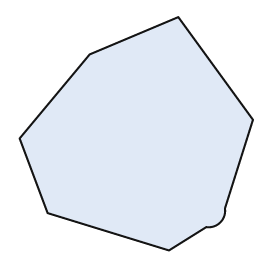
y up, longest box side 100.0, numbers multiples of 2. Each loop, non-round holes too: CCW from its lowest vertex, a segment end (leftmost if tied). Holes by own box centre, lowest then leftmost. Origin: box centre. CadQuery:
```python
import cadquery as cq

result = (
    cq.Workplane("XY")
    .moveTo(14.0, -50.0)
    .lineTo(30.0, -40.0)
    .threePointArc((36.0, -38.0), (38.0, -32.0))
    .lineTo(50.0, 6.0)
    .lineTo(18.0, 50.0)
    .lineTo(-20.0, 34.0)
    .lineTo(-50.0, -2.0)
    .lineTo(-38.0, -34.0)
    .close()
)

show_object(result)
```